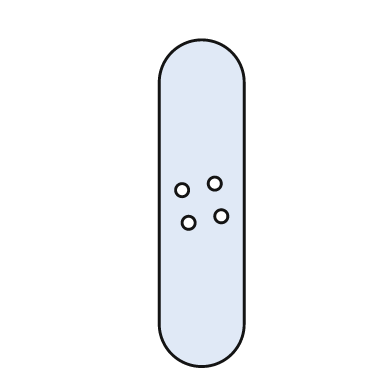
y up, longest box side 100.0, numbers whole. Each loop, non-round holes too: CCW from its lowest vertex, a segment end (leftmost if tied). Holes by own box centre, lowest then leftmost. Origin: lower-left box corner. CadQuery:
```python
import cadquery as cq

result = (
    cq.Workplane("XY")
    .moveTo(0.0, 13.0)
    .threePointArc((13.0, 0.0), (26.0, 13.0))
    .lineTo(26.0, 87.0)
    .threePointArc((13.0, 100.0), (0.0, 87.0))
    .close()
    .moveTo(9.0, 44.0)
    .circle(2.0)
    .moveTo(19.0, 46.0)
    .circle(2.0)
    .moveTo(7.0, 54.0)
    .circle(2.0)
    .moveTo(17.0, 56.0)
    .circle(2.0)
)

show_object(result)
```